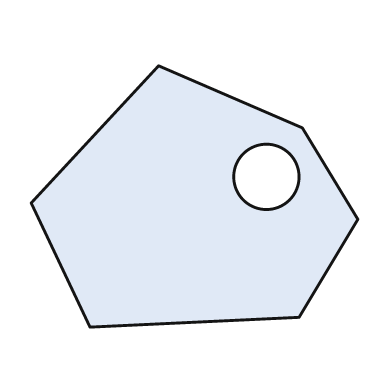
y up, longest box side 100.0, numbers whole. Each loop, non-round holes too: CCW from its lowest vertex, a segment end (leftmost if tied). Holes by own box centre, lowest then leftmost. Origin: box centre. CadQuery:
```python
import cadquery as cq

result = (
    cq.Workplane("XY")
    .moveTo(-32.0, -40.0)
    .lineTo(32.0, -37.0)
    .lineTo(50.0, -7.0)
    .lineTo(33.0, 21.0)
    .lineTo(-11.0, 40.0)
    .lineTo(-50.0, -2.0)
    .close()
    .moveTo(22.0, 6.0)
    .circle(10.0)
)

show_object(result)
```